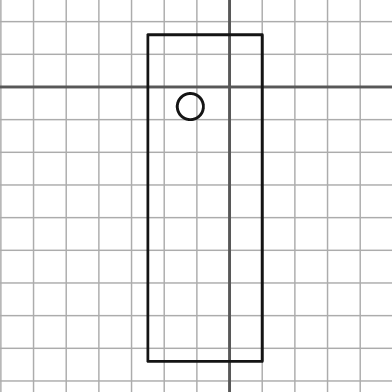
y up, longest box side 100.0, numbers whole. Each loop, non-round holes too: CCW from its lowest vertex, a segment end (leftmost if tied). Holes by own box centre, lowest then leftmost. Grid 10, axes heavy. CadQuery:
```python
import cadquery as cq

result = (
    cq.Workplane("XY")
    .moveTo(-25.0, -84.0)
    .lineTo(10.0, -84.0)
    .lineTo(10.0, 16.0)
    .lineTo(-25.0, 16.0)
    .close()
    .moveTo(-12.0, -6.0)
    .circle(4.0)
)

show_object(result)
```